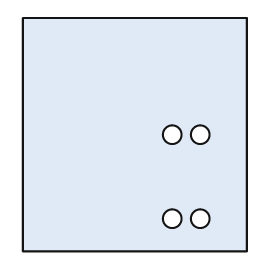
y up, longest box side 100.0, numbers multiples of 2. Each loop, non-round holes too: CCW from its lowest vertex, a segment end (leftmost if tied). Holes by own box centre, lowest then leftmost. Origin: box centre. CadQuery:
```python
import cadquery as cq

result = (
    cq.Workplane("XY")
    .moveTo(-48.0, -50.0)
    .lineTo(48.0, -50.0)
    .lineTo(48.0, 50.0)
    .lineTo(-48.0, 50.0)
    .close()
    .moveTo(16.0, -36.0)
    .circle(4.0)
    .moveTo(28.0, -36.0)
    .circle(4.0)
    .moveTo(16.0, 0.0)
    .circle(4.0)
    .moveTo(28.0, 0.0)
    .circle(4.0)
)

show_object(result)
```